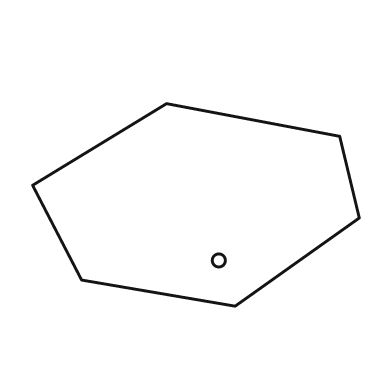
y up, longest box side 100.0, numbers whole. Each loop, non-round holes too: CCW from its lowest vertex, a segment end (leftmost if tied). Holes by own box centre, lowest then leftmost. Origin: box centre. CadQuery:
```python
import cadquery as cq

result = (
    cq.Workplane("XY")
    .moveTo(12.0, -31.0)
    .lineTo(50.0, -4.0)
    .lineTo(44.0, 21.0)
    .lineTo(-9.0, 31.0)
    .lineTo(-50.0, 6.0)
    .lineTo(-35.0, -23.0)
    .close()
    .moveTo(7.0, -17.0)
    .circle(2.0)
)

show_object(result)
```